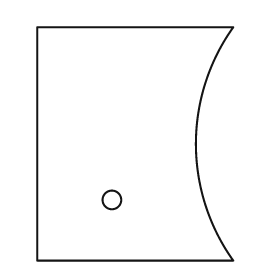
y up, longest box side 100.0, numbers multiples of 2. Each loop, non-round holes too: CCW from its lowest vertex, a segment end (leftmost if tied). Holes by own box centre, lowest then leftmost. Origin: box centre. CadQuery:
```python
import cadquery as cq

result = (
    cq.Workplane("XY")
    .moveTo(-42.0, -50.0)
    .lineTo(42.0, -50.0)
    .threePointArc((26.0, 0.0), (42.0, 50.0))
    .lineTo(-42.0, 50.0)
    .close()
    .moveTo(-10.0, -24.0)
    .circle(4.0)
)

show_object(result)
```